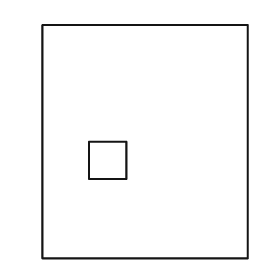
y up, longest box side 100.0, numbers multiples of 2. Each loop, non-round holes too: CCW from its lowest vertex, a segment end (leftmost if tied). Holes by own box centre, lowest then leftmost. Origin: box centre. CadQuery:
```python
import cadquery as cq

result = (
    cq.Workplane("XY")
    .moveTo(-44.0, -50.0)
    .lineTo(44.0, -50.0)
    .lineTo(44.0, 50.0)
    .lineTo(-44.0, 50.0)
    .close()
    .moveTo(-24.0, -16.0)
    .lineTo(-8.0, -16.0)
    .lineTo(-8.0, 0.0)
    .lineTo(-24.0, 0.0)
    .close()
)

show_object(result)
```